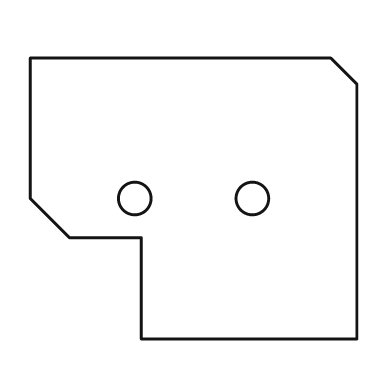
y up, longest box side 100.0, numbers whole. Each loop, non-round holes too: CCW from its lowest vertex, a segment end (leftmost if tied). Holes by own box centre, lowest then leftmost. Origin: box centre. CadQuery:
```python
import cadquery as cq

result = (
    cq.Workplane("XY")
    .moveTo(-16.0, -43.0)
    .lineTo(50.0, -43.0)
    .lineTo(50.0, 35.0)
    .lineTo(42.0, 43.0)
    .lineTo(-50.0, 43.0)
    .lineTo(-50.0, 0.0)
    .lineTo(-38.0, -12.0)
    .lineTo(-16.0, -12.0)
    .close()
    .moveTo(-18.0, 0.0)
    .circle(5.0)
    .moveTo(18.0, 0.0)
    .circle(5.0)
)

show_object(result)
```